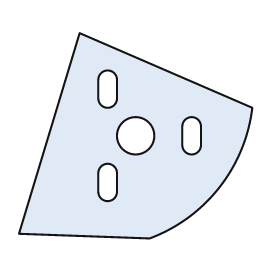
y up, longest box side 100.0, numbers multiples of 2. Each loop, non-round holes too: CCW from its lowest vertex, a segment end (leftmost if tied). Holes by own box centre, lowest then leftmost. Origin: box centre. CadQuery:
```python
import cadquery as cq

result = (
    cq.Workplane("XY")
    .moveTo(6.0, -44.0)
    .threePointArc((36.0, -22.0), (50.0, 12.0))
    .lineTo(-24.0, 44.0)
    .lineTo(-50.0, -42.0)
    .close()
    .moveTo(-16.0, -24.0)
    .threePointArc((-12.0, -28.0), (-8.0, -24.0))
    .lineTo(-8.0, -16.0)
    .threePointArc((-12.0, -12.0), (-16.0, -16.0))
    .close()
    .moveTo(0.0, 0.0)
    .circle(8.0)
    .moveTo(20.0, -4.0)
    .threePointArc((24.0, -8.0), (28.0, -4.0))
    .lineTo(28.0, 4.0)
    .threePointArc((24.0, 8.0), (20.0, 4.0))
    .close()
    .moveTo(-16.0, 16.0)
    .threePointArc((-12.0, 12.0), (-8.0, 16.0))
    .lineTo(-8.0, 24.0)
    .threePointArc((-12.0, 28.0), (-16.0, 24.0))
    .close()
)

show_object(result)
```